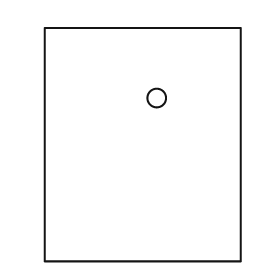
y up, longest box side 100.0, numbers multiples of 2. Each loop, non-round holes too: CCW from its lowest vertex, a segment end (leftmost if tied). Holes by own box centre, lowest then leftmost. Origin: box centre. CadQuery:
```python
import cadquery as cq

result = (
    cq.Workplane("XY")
    .moveTo(-42.0, -50.0)
    .lineTo(42.0, -50.0)
    .lineTo(42.0, 50.0)
    .lineTo(-42.0, 50.0)
    .close()
    .moveTo(6.0, 20.0)
    .circle(4.0)
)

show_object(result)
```